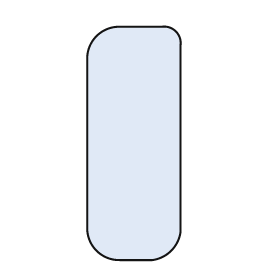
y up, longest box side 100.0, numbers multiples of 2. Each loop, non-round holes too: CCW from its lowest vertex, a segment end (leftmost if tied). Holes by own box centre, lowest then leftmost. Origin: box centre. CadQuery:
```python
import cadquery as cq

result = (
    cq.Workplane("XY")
    .moveTo(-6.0, -50.0)
    .lineTo(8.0, -50.0)
    .threePointArc((16.0, -46.0), (20.0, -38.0))
    .lineTo(20.0, 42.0)
    .threePointArc((18.0, 48.0), (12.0, 50.0))
    .lineTo(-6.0, 50.0)
    .threePointArc((-16.0, 46.0), (-20.0, 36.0))
    .lineTo(-20.0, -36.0)
    .threePointArc((-16.0, -46.0), (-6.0, -50.0))
    .close()
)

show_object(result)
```